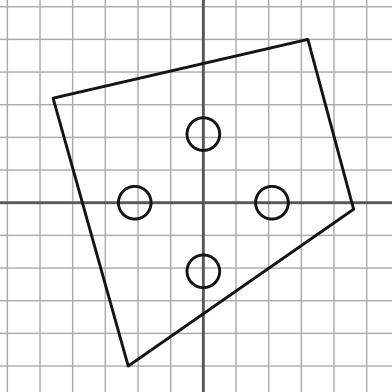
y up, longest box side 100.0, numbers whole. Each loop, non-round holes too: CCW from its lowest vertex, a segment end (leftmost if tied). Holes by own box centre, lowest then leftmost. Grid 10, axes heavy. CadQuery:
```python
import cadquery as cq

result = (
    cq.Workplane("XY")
    .moveTo(-23.0, -50.0)
    .lineTo(46.0, -2.0)
    .lineTo(32.0, 50.0)
    .lineTo(-46.0, 32.0)
    .close()
    .moveTo(0.0, -21.0)
    .circle(5.0)
    .moveTo(-21.0, 0.0)
    .circle(5.0)
    .moveTo(21.0, 0.0)
    .circle(5.0)
    .moveTo(0.0, 21.0)
    .circle(5.0)
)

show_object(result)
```